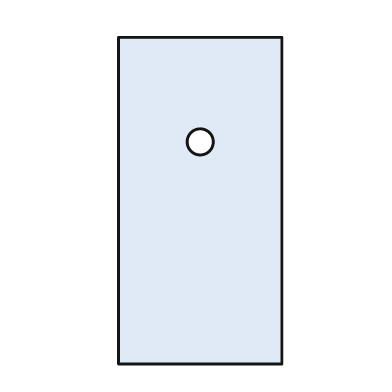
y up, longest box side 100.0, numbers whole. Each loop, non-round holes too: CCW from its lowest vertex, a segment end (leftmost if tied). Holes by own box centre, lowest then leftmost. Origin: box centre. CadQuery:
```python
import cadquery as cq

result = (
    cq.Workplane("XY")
    .moveTo(-25.0, -50.0)
    .lineTo(25.0, -50.0)
    .lineTo(25.0, 50.0)
    .lineTo(-25.0, 50.0)
    .close()
    .moveTo(0.0, 18.0)
    .circle(4.0)
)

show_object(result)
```